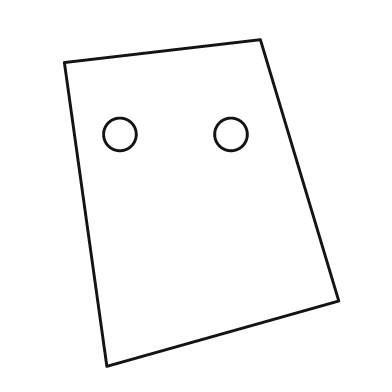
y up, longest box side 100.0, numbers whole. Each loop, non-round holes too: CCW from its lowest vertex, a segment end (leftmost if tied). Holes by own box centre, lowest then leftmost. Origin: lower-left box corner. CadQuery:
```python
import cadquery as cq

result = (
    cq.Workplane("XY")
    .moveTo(13.0, 0.0)
    .lineTo(84.0, 20.0)
    .lineTo(60.0, 100.0)
    .lineTo(0.0, 93.0)
    .close()
    .moveTo(17.0, 71.0)
    .circle(5.0)
    .moveTo(51.0, 71.0)
    .circle(5.0)
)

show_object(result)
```